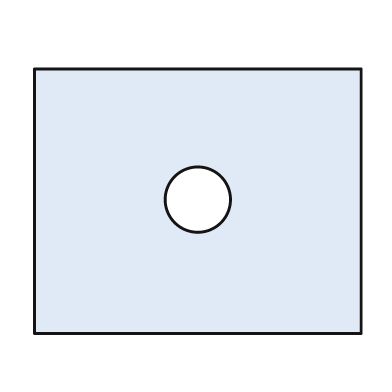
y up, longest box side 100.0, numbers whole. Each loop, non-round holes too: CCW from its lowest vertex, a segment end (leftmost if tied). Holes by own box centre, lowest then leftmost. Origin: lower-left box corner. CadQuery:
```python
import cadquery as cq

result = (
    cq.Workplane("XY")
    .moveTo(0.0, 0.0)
    .lineTo(100.0, 0.0)
    .lineTo(100.0, 81.0)
    .lineTo(0.0, 81.0)
    .close()
    .moveTo(50.0, 41.0)
    .circle(10.0)
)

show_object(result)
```